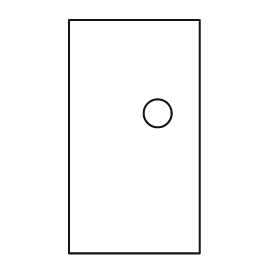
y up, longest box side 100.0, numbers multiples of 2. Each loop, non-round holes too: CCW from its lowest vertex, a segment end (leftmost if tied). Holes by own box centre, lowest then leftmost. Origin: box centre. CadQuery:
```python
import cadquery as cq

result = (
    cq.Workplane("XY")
    .moveTo(-28.0, -50.0)
    .lineTo(28.0, -50.0)
    .lineTo(28.0, 50.0)
    .lineTo(-28.0, 50.0)
    .close()
    .moveTo(10.0, 10.0)
    .circle(6.0)
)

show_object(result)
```